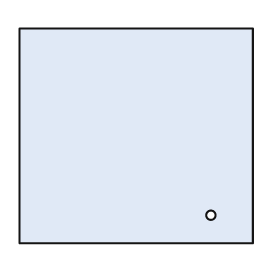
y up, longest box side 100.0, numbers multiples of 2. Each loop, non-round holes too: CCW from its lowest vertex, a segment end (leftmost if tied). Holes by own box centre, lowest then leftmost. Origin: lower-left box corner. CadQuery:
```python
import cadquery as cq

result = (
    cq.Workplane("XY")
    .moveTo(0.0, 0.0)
    .lineTo(100.0, 0.0)
    .lineTo(100.0, 92.0)
    .lineTo(0.0, 92.0)
    .close()
    .moveTo(82.0, 12.0)
    .circle(2.0)
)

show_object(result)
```